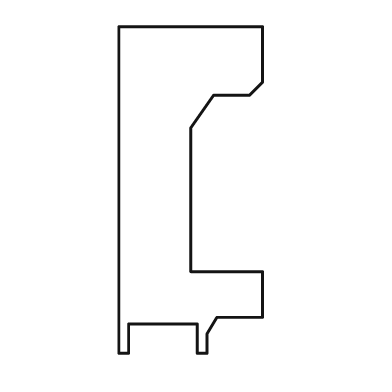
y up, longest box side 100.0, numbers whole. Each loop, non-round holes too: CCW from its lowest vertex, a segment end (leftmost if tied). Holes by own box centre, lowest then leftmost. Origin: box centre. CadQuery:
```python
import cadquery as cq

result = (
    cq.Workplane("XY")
    .moveTo(-22.0, -50.0)
    .lineTo(-19.0, -50.0)
    .lineTo(-19.0, -41.0)
    .lineTo(2.0, -41.0)
    .lineTo(2.0, -50.0)
    .lineTo(5.0, -50.0)
    .lineTo(5.0, -44.0)
    .lineTo(8.0, -39.0)
    .lineTo(22.0, -39.0)
    .lineTo(22.0, -25.0)
    .lineTo(0.0, -25.0)
    .lineTo(0.0, 19.0)
    .lineTo(7.0, 29.0)
    .lineTo(18.0, 29.0)
    .lineTo(22.0, 33.0)
    .lineTo(22.0, 50.0)
    .lineTo(-22.0, 50.0)
    .close()
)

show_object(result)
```